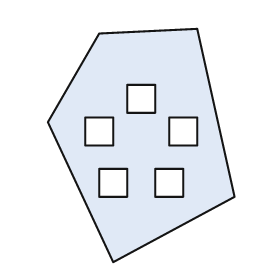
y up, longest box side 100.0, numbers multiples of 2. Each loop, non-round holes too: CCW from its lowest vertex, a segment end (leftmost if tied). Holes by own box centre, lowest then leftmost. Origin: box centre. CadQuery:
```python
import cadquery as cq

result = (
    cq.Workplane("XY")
    .moveTo(-12.0, -50.0)
    .lineTo(40.0, -22.0)
    .lineTo(24.0, 50.0)
    .lineTo(-18.0, 48.0)
    .lineTo(-40.0, 10.0)
    .close()
    .moveTo(-18.0, -22.0)
    .lineTo(-6.0, -22.0)
    .lineTo(-6.0, -10.0)
    .lineTo(-18.0, -10.0)
    .close()
    .moveTo(6.0, -22.0)
    .lineTo(18.0, -22.0)
    .lineTo(18.0, -10.0)
    .lineTo(6.0, -10.0)
    .close()
    .moveTo(-24.0, 0.0)
    .lineTo(-12.0, 0.0)
    .lineTo(-12.0, 12.0)
    .lineTo(-24.0, 12.0)
    .close()
    .moveTo(12.0, 0.0)
    .lineTo(24.0, 0.0)
    .lineTo(24.0, 12.0)
    .lineTo(12.0, 12.0)
    .close()
    .moveTo(-6.0, 14.0)
    .lineTo(6.0, 14.0)
    .lineTo(6.0, 26.0)
    .lineTo(-6.0, 26.0)
    .close()
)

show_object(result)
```